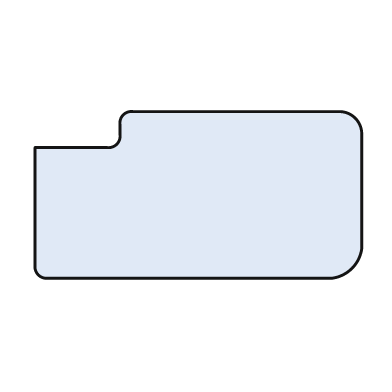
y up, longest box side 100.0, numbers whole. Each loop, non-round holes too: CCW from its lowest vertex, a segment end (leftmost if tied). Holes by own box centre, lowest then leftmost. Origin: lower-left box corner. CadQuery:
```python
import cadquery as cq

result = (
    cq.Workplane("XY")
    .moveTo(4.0, 0.0)
    .lineTo(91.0, 0.0)
    .threePointArc((97.0, 3.0), (100.0, 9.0))
    .lineTo(100.0, 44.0)
    .threePointArc((98.0, 49.0), (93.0, 51.0))
    .lineTo(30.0, 51.0)
    .threePointArc((27.0, 50.0), (26.0, 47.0))
    .lineTo(26.0, 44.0)
    .threePointArc((25.0, 41.0), (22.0, 40.0))
    .lineTo(0.0, 40.0)
    .lineTo(0.0, 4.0)
    .threePointArc((1.0, 1.0), (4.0, 0.0))
    .close()
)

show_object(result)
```